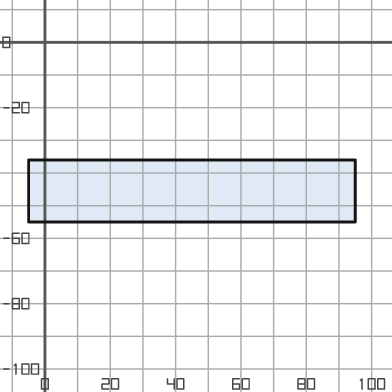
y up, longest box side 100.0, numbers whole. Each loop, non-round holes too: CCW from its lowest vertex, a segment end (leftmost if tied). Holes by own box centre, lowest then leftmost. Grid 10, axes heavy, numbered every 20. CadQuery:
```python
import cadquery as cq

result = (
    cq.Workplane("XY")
    .moveTo(-5.0, -55.0)
    .lineTo(95.0, -55.0)
    .lineTo(95.0, -36.0)
    .lineTo(-5.0, -36.0)
    .close()
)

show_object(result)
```